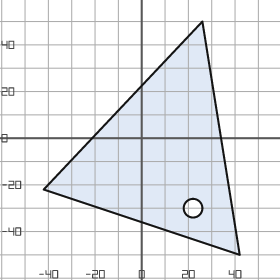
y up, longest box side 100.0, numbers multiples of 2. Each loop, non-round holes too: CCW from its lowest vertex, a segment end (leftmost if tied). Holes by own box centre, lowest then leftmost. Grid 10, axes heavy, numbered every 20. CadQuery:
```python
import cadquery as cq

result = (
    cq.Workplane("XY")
    .moveTo(42.0, -50.0)
    .lineTo(26.0, 50.0)
    .lineTo(-42.0, -22.0)
    .close()
    .moveTo(22.0, -30.0)
    .circle(4.0)
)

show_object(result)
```